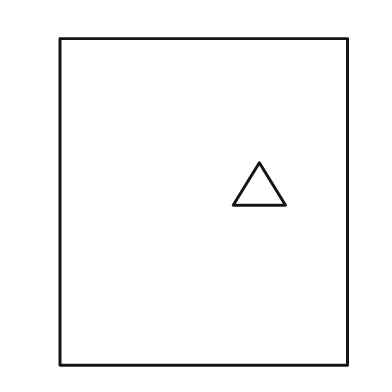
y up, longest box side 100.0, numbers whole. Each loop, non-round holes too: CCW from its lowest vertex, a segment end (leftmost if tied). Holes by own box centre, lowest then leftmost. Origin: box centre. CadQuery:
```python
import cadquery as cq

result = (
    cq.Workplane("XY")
    .moveTo(-44.0, -50.0)
    .lineTo(44.0, -50.0)
    .lineTo(44.0, 50.0)
    .lineTo(-44.0, 50.0)
    .close()
    .moveTo(9.0, -1.0)
    .lineTo(25.0, -1.0)
    .lineTo(17.0, 12.0)
    .close()
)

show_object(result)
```